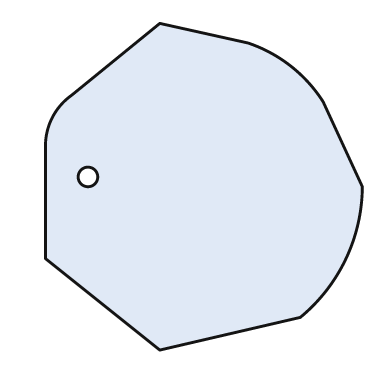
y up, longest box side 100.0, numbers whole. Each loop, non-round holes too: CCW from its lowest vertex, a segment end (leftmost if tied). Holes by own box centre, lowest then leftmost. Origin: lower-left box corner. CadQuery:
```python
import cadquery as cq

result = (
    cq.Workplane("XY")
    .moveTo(35.0, 0.0)
    .lineTo(78.0, 10.0)
    .threePointArc((92.0, 28.0), (97.0, 50.0))
    .lineTo(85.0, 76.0)
    .threePointArc((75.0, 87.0), (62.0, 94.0))
    .lineTo(35.0, 100.0)
    .lineTo(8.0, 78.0)
    .threePointArc((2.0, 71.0), (0.0, 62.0))
    .lineTo(0.0, 28.0)
    .close()
    .moveTo(13.0, 53.0)
    .circle(3.0)
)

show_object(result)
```